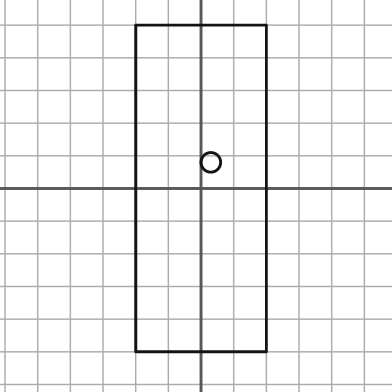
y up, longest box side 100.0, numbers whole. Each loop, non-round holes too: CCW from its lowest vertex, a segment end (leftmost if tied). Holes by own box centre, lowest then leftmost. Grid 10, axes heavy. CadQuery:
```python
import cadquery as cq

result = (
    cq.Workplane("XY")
    .moveTo(-20.0, -50.0)
    .lineTo(20.0, -50.0)
    .lineTo(20.0, 50.0)
    .lineTo(-20.0, 50.0)
    .close()
    .moveTo(3.0, 8.0)
    .circle(3.0)
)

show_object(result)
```